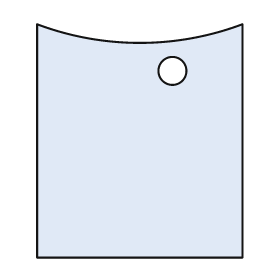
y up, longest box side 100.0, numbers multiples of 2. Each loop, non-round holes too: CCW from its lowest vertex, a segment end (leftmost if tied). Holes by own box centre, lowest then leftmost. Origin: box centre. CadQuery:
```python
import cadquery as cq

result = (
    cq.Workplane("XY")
    .moveTo(-44.0, -50.0)
    .lineTo(44.0, -50.0)
    .lineTo(44.0, 50.0)
    .threePointArc((0.0, 42.0), (-44.0, 50.0))
    .close()
    .moveTo(14.0, 30.0)
    .circle(6.0)
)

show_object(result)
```